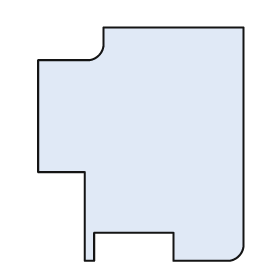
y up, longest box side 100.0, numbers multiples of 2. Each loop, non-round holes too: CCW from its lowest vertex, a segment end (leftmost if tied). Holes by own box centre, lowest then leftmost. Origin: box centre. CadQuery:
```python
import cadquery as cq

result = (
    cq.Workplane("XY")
    .moveTo(-24.0, -50.0)
    .lineTo(-20.0, -50.0)
    .lineTo(-20.0, -38.0)
    .lineTo(14.0, -38.0)
    .lineTo(14.0, -50.0)
    .lineTo(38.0, -50.0)
    .threePointArc((42.0, -48.0), (44.0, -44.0))
    .lineTo(44.0, 50.0)
    .lineTo(-16.0, 50.0)
    .lineTo(-16.0, 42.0)
    .threePointArc((-18.0, 38.0), (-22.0, 36.0))
    .lineTo(-44.0, 36.0)
    .lineTo(-44.0, -12.0)
    .lineTo(-24.0, -12.0)
    .close()
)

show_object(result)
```